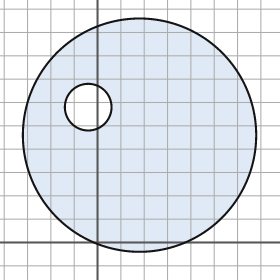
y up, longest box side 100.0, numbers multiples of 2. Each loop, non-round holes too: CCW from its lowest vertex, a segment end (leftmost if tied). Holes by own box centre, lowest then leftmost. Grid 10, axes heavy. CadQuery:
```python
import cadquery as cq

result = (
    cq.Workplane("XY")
    .moveTo(18.0, 46.0)
    .circle(50.0)
    .moveTo(-4.0, 58.0)
    .circle(10.0)
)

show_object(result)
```